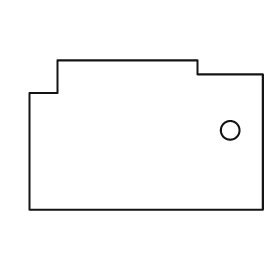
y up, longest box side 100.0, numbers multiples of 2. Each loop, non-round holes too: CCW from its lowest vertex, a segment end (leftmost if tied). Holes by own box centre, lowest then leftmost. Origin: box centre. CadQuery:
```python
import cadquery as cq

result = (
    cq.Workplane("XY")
    .moveTo(-50.0, -32.0)
    .lineTo(50.0, -32.0)
    .lineTo(50.0, 26.0)
    .lineTo(22.0, 26.0)
    .lineTo(22.0, 32.0)
    .lineTo(-38.0, 32.0)
    .lineTo(-38.0, 18.0)
    .lineTo(-50.0, 18.0)
    .close()
    .moveTo(36.0, 2.0)
    .circle(4.0)
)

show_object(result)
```